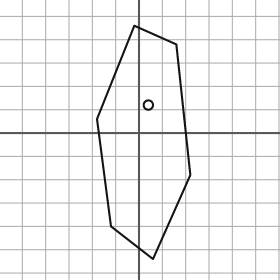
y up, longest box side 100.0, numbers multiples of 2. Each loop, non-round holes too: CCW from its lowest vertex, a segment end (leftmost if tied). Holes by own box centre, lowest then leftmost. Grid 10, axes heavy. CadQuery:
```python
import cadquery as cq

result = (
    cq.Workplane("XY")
    .moveTo(6.0, -54.0)
    .lineTo(22.0, -18.0)
    .lineTo(16.0, 38.0)
    .lineTo(-2.0, 46.0)
    .lineTo(-18.0, 6.0)
    .lineTo(-12.0, -40.0)
    .close()
    .moveTo(4.0, 12.0)
    .circle(2.0)
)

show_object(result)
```